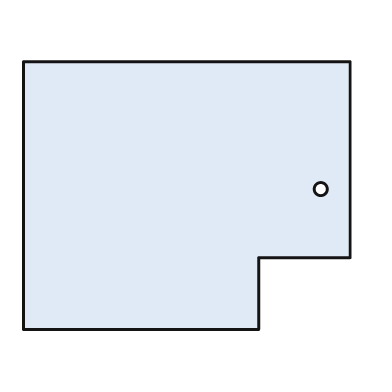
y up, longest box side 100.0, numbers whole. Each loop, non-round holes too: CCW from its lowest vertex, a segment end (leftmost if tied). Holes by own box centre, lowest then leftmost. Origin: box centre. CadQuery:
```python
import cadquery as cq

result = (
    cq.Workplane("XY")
    .moveTo(-50.0, -41.0)
    .lineTo(22.0, -41.0)
    .lineTo(22.0, -19.0)
    .lineTo(50.0, -19.0)
    .lineTo(50.0, 41.0)
    .lineTo(-50.0, 41.0)
    .close()
    .moveTo(41.0, 2.0)
    .circle(2.0)
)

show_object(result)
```